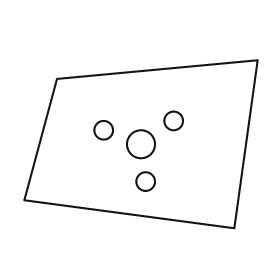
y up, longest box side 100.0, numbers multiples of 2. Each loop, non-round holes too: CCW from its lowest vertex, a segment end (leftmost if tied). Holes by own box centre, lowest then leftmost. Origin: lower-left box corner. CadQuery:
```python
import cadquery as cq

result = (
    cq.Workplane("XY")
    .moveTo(90.0, 0.0)
    .lineTo(100.0, 72.0)
    .lineTo(14.0, 64.0)
    .lineTo(0.0, 12.0)
    .close()
    .moveTo(52.0, 20.0)
    .circle(4.0)
    .moveTo(50.0, 36.0)
    .circle(6.0)
    .moveTo(34.0, 42.0)
    .circle(4.0)
    .moveTo(64.0, 46.0)
    .circle(4.0)
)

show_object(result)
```